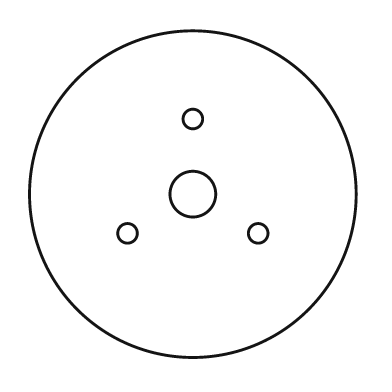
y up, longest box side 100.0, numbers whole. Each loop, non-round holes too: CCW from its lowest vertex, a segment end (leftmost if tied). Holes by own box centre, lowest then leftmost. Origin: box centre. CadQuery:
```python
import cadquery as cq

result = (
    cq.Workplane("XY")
    .moveTo(0.0, 0.0)
    .circle(50.0)
    .moveTo(-20.0, -12.0)
    .circle(3.0)
    .moveTo(20.0, -12.0)
    .circle(3.0)
    .moveTo(0.0, 0.0)
    .circle(7.0)
    .moveTo(0.0, 23.0)
    .circle(3.0)
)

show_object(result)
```